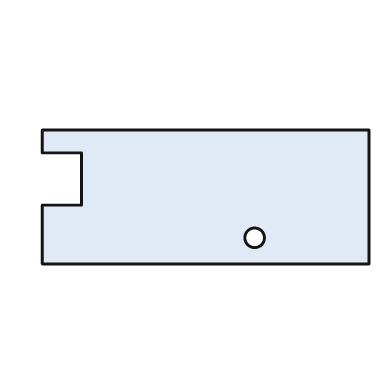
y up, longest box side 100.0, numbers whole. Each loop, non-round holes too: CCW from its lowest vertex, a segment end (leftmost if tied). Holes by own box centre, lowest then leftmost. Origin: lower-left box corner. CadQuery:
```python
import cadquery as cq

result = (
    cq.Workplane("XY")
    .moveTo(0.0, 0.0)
    .lineTo(100.0, 0.0)
    .lineTo(100.0, 41.0)
    .lineTo(0.0, 41.0)
    .lineTo(0.0, 34.0)
    .lineTo(12.0, 34.0)
    .lineTo(12.0, 18.0)
    .lineTo(0.0, 18.0)
    .close()
    .moveTo(65.0, 8.0)
    .circle(3.0)
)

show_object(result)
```